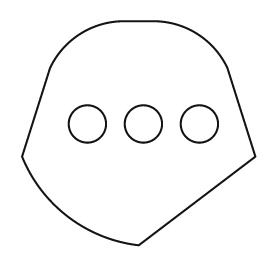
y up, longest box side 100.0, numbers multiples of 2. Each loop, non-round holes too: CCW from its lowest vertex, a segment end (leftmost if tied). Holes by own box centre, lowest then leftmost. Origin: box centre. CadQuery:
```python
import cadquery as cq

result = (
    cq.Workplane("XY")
    .moveTo(0.0, -48.0)
    .lineTo(50.0, -10.0)
    .lineTo(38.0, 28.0)
    .threePointArc((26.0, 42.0), (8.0, 48.0))
    .lineTo(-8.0, 48.0)
    .threePointArc((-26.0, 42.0), (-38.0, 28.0))
    .lineTo(-50.0, -10.0)
    .threePointArc((-30.0, -36.0), (0.0, -48.0))
    .close()
    .moveTo(-22.0, 4.0)
    .circle(8.0)
    .moveTo(2.0, 4.0)
    .circle(8.0)
    .moveTo(26.0, 4.0)
    .circle(8.0)
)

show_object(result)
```